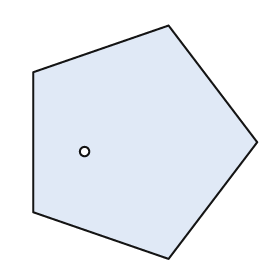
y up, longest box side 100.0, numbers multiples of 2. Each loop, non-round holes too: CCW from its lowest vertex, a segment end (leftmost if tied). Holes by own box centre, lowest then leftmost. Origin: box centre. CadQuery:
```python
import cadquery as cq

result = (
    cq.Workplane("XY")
    .moveTo(10.0, -50.0)
    .lineTo(48.0, 0.0)
    .lineTo(10.0, 50.0)
    .lineTo(-48.0, 30.0)
    .lineTo(-48.0, -30.0)
    .close()
    .moveTo(-26.0, -4.0)
    .circle(2.0)
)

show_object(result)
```